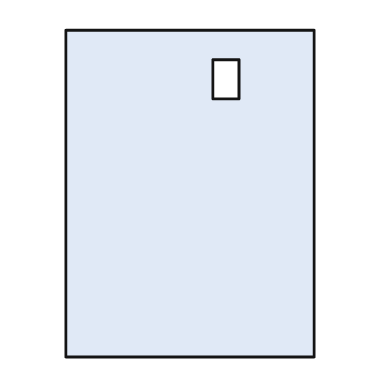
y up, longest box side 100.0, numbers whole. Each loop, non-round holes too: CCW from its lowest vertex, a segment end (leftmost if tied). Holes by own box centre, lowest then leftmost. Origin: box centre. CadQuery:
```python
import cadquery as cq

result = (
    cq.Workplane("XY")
    .moveTo(-38.0, -50.0)
    .lineTo(38.0, -50.0)
    .lineTo(38.0, 50.0)
    .lineTo(-38.0, 50.0)
    .close()
    .moveTo(7.0, 29.0)
    .lineTo(15.0, 29.0)
    .lineTo(15.0, 41.0)
    .lineTo(7.0, 41.0)
    .close()
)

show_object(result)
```